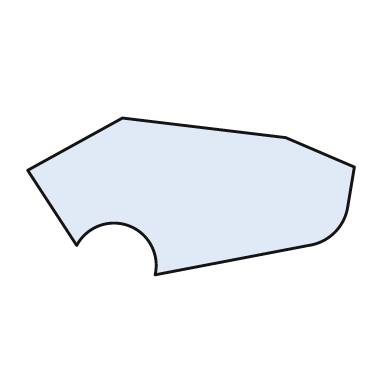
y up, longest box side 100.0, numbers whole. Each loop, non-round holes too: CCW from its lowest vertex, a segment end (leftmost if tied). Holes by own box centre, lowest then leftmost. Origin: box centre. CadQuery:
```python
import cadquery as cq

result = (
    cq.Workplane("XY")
    .moveTo(-11.0, -24.0)
    .lineTo(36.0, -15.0)
    .threePointArc((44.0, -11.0), (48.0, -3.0))
    .lineTo(50.0, 9.0)
    .lineTo(29.0, 18.0)
    .lineTo(-21.0, 24.0)
    .lineTo(-50.0, 8.0)
    .lineTo(-35.0, -15.0)
    .threePointArc((-19.0, -9.0), (-11.0, -24.0))
    .close()
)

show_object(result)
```